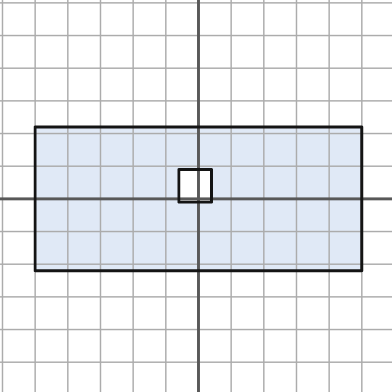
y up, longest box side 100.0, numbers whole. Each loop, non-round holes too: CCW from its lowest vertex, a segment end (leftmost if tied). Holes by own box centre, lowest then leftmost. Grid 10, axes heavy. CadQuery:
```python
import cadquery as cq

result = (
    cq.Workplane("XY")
    .moveTo(-50.0, -22.0)
    .lineTo(50.0, -22.0)
    .lineTo(50.0, 22.0)
    .lineTo(-50.0, 22.0)
    .close()
    .moveTo(-6.0, -1.0)
    .lineTo(4.0, -1.0)
    .lineTo(4.0, 9.0)
    .lineTo(-6.0, 9.0)
    .close()
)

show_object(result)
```